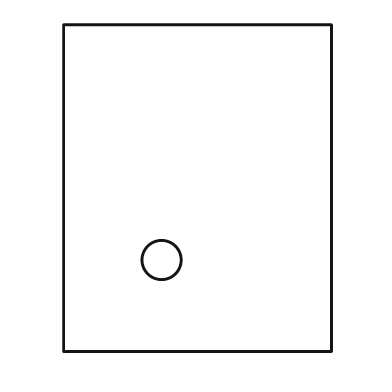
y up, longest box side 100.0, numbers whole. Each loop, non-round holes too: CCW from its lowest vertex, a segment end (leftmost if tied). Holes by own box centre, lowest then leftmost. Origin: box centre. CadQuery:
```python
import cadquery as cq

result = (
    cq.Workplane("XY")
    .moveTo(-41.0, -50.0)
    .lineTo(41.0, -50.0)
    .lineTo(41.0, 50.0)
    .lineTo(-41.0, 50.0)
    .close()
    .moveTo(-11.0, -22.0)
    .circle(6.0)
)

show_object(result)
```